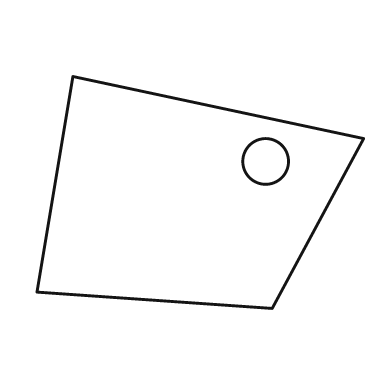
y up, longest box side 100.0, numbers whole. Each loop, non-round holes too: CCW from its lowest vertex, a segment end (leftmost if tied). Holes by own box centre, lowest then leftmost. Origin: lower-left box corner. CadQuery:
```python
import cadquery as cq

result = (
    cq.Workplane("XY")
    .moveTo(72.0, 0.0)
    .lineTo(100.0, 52.0)
    .lineTo(11.0, 71.0)
    .lineTo(0.0, 5.0)
    .close()
    .moveTo(70.0, 45.0)
    .circle(7.0)
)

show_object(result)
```